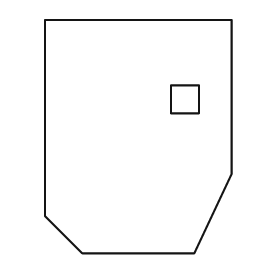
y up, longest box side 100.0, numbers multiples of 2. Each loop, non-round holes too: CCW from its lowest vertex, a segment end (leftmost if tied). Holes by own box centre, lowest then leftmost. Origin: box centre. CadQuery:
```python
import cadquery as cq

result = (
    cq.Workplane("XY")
    .moveTo(-24.0, -50.0)
    .lineTo(24.0, -50.0)
    .lineTo(40.0, -16.0)
    .lineTo(40.0, 50.0)
    .lineTo(-40.0, 50.0)
    .lineTo(-40.0, -34.0)
    .close()
    .moveTo(14.0, 10.0)
    .lineTo(26.0, 10.0)
    .lineTo(26.0, 22.0)
    .lineTo(14.0, 22.0)
    .close()
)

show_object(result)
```